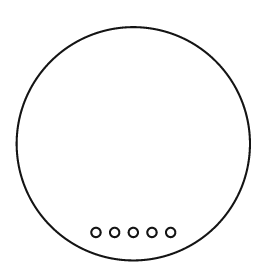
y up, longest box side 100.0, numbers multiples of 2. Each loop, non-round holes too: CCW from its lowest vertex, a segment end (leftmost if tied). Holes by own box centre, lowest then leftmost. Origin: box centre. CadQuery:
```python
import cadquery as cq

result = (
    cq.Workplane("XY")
    .moveTo(0.0, 0.0)
    .circle(50.0)
    .moveTo(-16.0, -38.0)
    .circle(2.0)
    .moveTo(-8.0, -38.0)
    .circle(2.0)
    .moveTo(0.0, -38.0)
    .circle(2.0)
    .moveTo(8.0, -38.0)
    .circle(2.0)
    .moveTo(16.0, -38.0)
    .circle(2.0)
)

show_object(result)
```